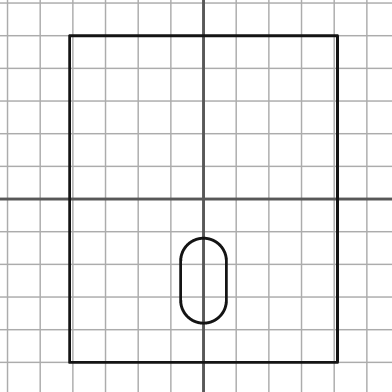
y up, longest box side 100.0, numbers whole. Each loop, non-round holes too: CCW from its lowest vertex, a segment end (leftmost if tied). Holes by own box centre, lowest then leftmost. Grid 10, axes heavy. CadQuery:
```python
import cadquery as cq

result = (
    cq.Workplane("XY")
    .moveTo(-41.0, -50.0)
    .lineTo(41.0, -50.0)
    .lineTo(41.0, 50.0)
    .lineTo(-41.0, 50.0)
    .close()
    .moveTo(-7.0, -31.0)
    .threePointArc((0.0, -38.0), (7.0, -31.0))
    .lineTo(7.0, -19.0)
    .threePointArc((0.0, -12.0), (-7.0, -19.0))
    .close()
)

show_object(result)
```